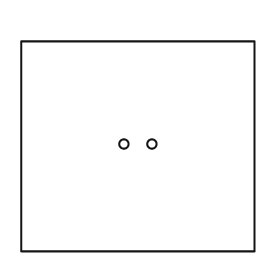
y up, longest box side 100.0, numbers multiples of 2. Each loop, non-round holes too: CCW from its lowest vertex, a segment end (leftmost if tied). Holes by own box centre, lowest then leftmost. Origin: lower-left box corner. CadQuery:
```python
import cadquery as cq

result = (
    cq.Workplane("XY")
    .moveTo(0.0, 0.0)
    .lineTo(100.0, 0.0)
    .lineTo(100.0, 90.0)
    .lineTo(0.0, 90.0)
    .close()
    .moveTo(44.0, 46.0)
    .circle(2.0)
    .moveTo(56.0, 46.0)
    .circle(2.0)
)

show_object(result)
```